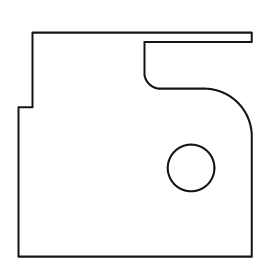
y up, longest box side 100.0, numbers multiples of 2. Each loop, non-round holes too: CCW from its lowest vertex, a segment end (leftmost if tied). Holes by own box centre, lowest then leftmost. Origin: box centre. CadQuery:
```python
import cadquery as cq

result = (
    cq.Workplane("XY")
    .moveTo(-50.0, -48.0)
    .lineTo(50.0, -48.0)
    .lineTo(50.0, 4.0)
    .threePointArc((44.0, 18.0), (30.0, 24.0))
    .lineTo(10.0, 24.0)
    .threePointArc((6.0, 26.0), (4.0, 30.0))
    .lineTo(4.0, 44.0)
    .lineTo(50.0, 44.0)
    .lineTo(50.0, 48.0)
    .lineTo(-44.0, 48.0)
    .lineTo(-44.0, 16.0)
    .lineTo(-50.0, 16.0)
    .close()
    .moveTo(24.0, -10.0)
    .circle(10.0)
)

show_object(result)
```